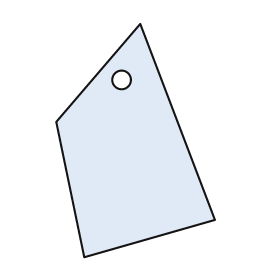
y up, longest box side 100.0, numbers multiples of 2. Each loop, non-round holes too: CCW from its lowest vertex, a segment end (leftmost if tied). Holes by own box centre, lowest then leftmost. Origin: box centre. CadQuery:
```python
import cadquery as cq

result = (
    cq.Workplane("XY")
    .moveTo(-22.0, -50.0)
    .lineTo(34.0, -34.0)
    .lineTo(2.0, 50.0)
    .lineTo(-34.0, 8.0)
    .close()
    .moveTo(-6.0, 26.0)
    .circle(4.0)
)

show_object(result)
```